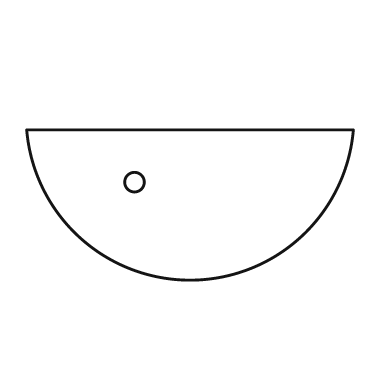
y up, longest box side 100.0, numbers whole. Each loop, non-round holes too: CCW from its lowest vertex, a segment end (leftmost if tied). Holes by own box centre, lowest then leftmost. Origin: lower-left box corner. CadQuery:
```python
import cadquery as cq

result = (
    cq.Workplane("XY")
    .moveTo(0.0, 46.0)
    .threePointArc((50.0, 0.0), (100.0, 46.0))
    .close()
    .moveTo(33.0, 30.0)
    .circle(3.0)
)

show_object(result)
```